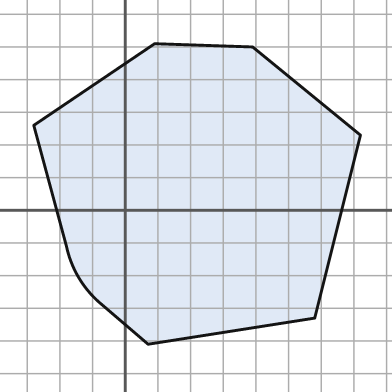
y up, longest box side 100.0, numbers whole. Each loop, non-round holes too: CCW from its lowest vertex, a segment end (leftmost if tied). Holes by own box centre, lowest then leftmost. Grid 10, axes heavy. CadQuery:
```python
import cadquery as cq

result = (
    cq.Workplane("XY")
    .moveTo(7.0, -41.0)
    .lineTo(58.0, -33.0)
    .lineTo(72.0, 23.0)
    .lineTo(39.0, 50.0)
    .lineTo(9.0, 51.0)
    .lineTo(-28.0, 26.0)
    .lineTo(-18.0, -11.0)
    .threePointArc((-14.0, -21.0), (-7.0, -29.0))
    .close()
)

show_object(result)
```